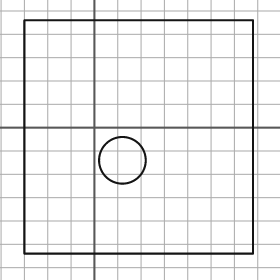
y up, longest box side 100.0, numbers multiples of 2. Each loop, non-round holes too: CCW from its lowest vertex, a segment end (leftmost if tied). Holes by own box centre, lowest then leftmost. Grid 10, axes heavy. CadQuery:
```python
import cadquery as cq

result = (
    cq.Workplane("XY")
    .moveTo(-30.0, -54.0)
    .lineTo(68.0, -54.0)
    .lineTo(68.0, 46.0)
    .lineTo(-30.0, 46.0)
    .close()
    .moveTo(12.0, -14.0)
    .circle(10.0)
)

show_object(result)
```